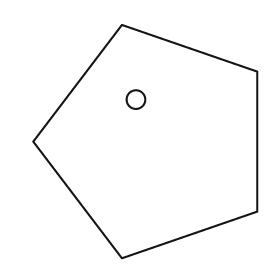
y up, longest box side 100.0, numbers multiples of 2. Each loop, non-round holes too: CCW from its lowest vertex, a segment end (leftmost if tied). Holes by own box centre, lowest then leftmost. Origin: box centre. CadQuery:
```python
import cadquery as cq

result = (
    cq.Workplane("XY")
    .moveTo(-10.0, -50.0)
    .lineTo(48.0, -30.0)
    .lineTo(48.0, 30.0)
    .lineTo(-10.0, 50.0)
    .lineTo(-48.0, 0.0)
    .close()
    .moveTo(-4.0, 18.0)
    .circle(4.0)
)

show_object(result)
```